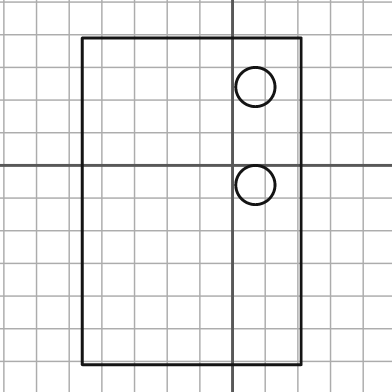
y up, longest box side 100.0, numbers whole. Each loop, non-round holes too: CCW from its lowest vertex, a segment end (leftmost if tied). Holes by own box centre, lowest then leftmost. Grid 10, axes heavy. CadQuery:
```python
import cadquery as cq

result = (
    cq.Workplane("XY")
    .moveTo(-46.0, -61.0)
    .lineTo(21.0, -61.0)
    .lineTo(21.0, 39.0)
    .lineTo(-46.0, 39.0)
    .close()
    .moveTo(7.0, -6.0)
    .circle(6.0)
    .moveTo(7.0, 24.0)
    .circle(6.0)
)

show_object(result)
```